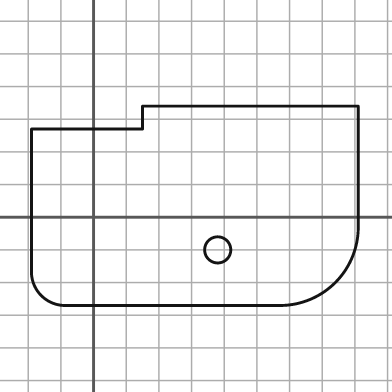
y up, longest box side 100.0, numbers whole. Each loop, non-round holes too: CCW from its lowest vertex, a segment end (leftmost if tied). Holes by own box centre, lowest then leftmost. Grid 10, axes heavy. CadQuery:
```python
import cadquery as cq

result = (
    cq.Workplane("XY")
    .moveTo(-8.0, -27.0)
    .lineTo(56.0, -27.0)
    .threePointArc((74.0, -20.0), (81.0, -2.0))
    .lineTo(81.0, 34.0)
    .lineTo(15.0, 34.0)
    .lineTo(15.0, 27.0)
    .lineTo(-19.0, 27.0)
    .lineTo(-19.0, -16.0)
    .threePointArc((-16.0, -24.0), (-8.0, -27.0))
    .close()
    .moveTo(38.0, -10.0)
    .circle(4.0)
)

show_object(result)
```